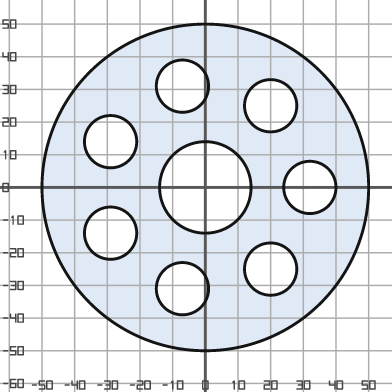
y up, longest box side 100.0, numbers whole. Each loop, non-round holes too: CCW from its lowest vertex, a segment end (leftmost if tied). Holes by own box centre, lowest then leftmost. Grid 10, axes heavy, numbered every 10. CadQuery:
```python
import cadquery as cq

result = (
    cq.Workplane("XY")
    .moveTo(0.0, 0.0)
    .circle(50.0)
    .moveTo(-7.0, -31.0)
    .circle(8.0)
    .moveTo(20.0, -25.0)
    .circle(8.0)
    .moveTo(-29.0, -14.0)
    .circle(8.0)
    .moveTo(0.0, 0.0)
    .circle(14.0)
    .moveTo(32.0, 0.0)
    .circle(8.0)
    .moveTo(-29.0, 14.0)
    .circle(8.0)
    .moveTo(20.0, 25.0)
    .circle(8.0)
    .moveTo(-7.0, 31.0)
    .circle(8.0)
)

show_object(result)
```